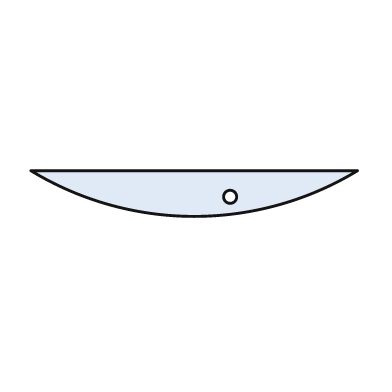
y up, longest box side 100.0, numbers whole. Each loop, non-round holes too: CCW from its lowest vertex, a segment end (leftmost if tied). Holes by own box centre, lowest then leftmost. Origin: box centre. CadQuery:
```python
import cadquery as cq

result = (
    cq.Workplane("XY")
    .moveTo(-50.0, 7.0)
    .threePointArc((0.0, -7.0), (50.0, 7.0))
    .close()
    .moveTo(11.0, -1.0)
    .circle(2.0)
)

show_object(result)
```